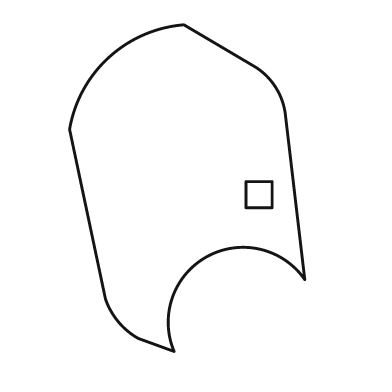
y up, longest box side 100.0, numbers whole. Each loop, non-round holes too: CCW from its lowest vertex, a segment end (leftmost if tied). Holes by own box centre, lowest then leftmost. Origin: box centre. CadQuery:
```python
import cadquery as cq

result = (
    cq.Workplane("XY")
    .moveTo(-4.0, -50.0)
    .threePointArc((6.0, -21.0), (36.0, -28.0))
    .lineTo(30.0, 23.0)
    .threePointArc((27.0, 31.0), (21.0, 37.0))
    .lineTo(-1.0, 50.0)
    .threePointArc((-24.0, 40.0), (-36.0, 18.0))
    .lineTo(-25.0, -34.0)
    .threePointArc((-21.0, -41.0), (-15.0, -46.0))
    .close()
    .moveTo(18.0, -6.0)
    .lineTo(26.0, -6.0)
    .lineTo(26.0, 2.0)
    .lineTo(18.0, 2.0)
    .close()
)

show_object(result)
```